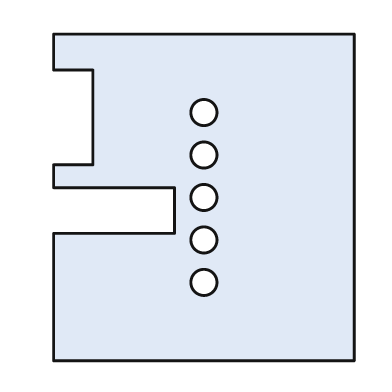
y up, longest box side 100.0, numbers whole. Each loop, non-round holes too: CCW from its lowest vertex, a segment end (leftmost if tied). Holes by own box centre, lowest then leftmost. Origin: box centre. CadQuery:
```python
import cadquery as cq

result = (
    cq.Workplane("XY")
    .moveTo(-46.0, -50.0)
    .lineTo(46.0, -50.0)
    .lineTo(46.0, 50.0)
    .lineTo(-46.0, 50.0)
    .lineTo(-46.0, 39.0)
    .lineTo(-34.0, 39.0)
    .lineTo(-34.0, 10.0)
    .lineTo(-46.0, 10.0)
    .lineTo(-46.0, 3.0)
    .lineTo(-9.0, 3.0)
    .lineTo(-9.0, -11.0)
    .lineTo(-46.0, -11.0)
    .close()
    .moveTo(0.0, -26.0)
    .circle(4.0)
    .moveTo(0.0, -13.0)
    .circle(4.0)
    .moveTo(0.0, 0.0)
    .circle(4.0)
    .moveTo(0.0, 13.0)
    .circle(4.0)
    .moveTo(0.0, 26.0)
    .circle(4.0)
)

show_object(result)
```